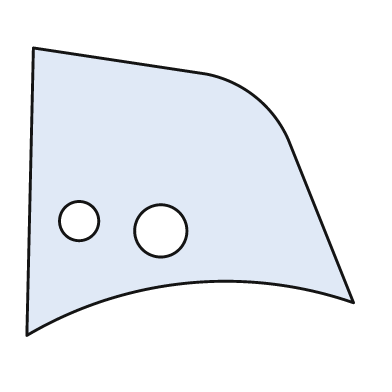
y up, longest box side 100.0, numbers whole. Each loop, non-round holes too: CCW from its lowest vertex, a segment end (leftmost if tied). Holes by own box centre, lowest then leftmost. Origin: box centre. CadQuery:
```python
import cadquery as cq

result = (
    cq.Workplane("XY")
    .moveTo(-50.0, -44.0)
    .threePointArc((-1.0, -28.0), (50.0, -34.0))
    .lineTo(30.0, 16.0)
    .threePointArc((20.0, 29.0), (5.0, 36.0))
    .lineTo(-48.0, 44.0)
    .close()
    .moveTo(-9.0, -12.0)
    .circle(8.0)
    .moveTo(-34.0, -9.0)
    .circle(6.0)
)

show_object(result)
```